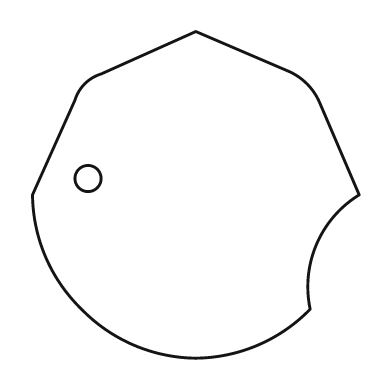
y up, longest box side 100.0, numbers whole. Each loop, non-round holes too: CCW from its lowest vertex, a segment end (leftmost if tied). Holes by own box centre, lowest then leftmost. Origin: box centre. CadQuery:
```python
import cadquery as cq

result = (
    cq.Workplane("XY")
    .moveTo(0.0, -50.0)
    .threePointArc((19.0, -46.0), (35.0, -35.0))
    .threePointArc((37.0, -15.0), (50.0, 0.0))
    .lineTo(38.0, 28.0)
    .threePointArc((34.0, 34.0), (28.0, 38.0))
    .lineTo(0.0, 50.0)
    .lineTo(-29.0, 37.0)
    .threePointArc((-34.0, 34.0), (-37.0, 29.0))
    .lineTo(-50.0, 0.0)
    .threePointArc((-46.0, -19.0), (-35.0, -35.0))
    .threePointArc((-19.0, -46.0), (0.0, -50.0))
    .close()
    .moveTo(-33.0, 5.0)
    .circle(4.0)
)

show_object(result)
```